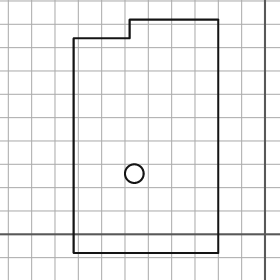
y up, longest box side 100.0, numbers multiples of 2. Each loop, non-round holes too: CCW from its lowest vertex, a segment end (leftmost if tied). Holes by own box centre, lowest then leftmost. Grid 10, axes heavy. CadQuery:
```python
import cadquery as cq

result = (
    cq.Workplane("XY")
    .moveTo(-82.0, -8.0)
    .lineTo(-20.0, -8.0)
    .lineTo(-20.0, 92.0)
    .lineTo(-58.0, 92.0)
    .lineTo(-58.0, 84.0)
    .lineTo(-82.0, 84.0)
    .close()
    .moveTo(-56.0, 26.0)
    .circle(4.0)
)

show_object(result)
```